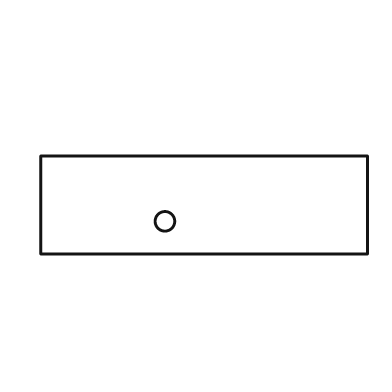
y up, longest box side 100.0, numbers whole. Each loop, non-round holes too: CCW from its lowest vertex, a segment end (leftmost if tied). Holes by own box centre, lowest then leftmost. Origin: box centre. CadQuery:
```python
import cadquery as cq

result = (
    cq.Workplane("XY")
    .moveTo(-50.0, -15.0)
    .lineTo(50.0, -15.0)
    .lineTo(50.0, 15.0)
    .lineTo(-50.0, 15.0)
    .close()
    .moveTo(-12.0, -5.0)
    .circle(3.0)
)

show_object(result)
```